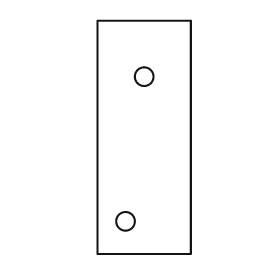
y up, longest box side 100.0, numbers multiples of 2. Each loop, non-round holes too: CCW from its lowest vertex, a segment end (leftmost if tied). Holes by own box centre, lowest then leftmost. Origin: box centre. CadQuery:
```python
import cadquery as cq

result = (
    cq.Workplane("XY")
    .moveTo(-20.0, -50.0)
    .lineTo(20.0, -50.0)
    .lineTo(20.0, 50.0)
    .lineTo(-20.0, 50.0)
    .close()
    .moveTo(-8.0, -36.0)
    .circle(4.0)
    .moveTo(0.0, 26.0)
    .circle(4.0)
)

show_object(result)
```